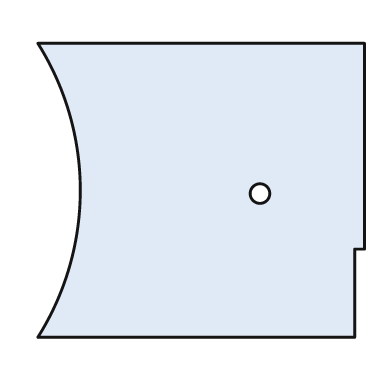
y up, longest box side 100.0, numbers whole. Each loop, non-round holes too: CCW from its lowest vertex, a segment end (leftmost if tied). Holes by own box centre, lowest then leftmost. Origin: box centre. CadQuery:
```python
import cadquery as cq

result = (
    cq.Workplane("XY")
    .moveTo(-50.0, -45.0)
    .lineTo(47.0, -45.0)
    .lineTo(47.0, -18.0)
    .lineTo(50.0, -18.0)
    .lineTo(50.0, 45.0)
    .lineTo(-50.0, 45.0)
    .threePointArc((-37.0, 0.0), (-50.0, -45.0))
    .close()
    .moveTo(18.0, -1.0)
    .circle(3.0)
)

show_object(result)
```